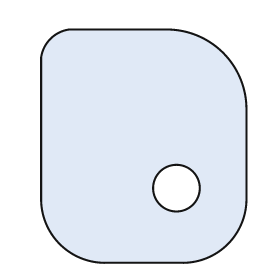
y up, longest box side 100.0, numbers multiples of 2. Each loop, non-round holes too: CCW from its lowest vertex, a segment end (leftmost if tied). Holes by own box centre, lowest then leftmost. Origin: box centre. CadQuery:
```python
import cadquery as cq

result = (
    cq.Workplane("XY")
    .moveTo(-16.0, -50.0)
    .lineTo(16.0, -50.0)
    .threePointArc((36.0, -42.0), (44.0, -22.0))
    .lineTo(44.0, 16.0)
    .threePointArc((34.0, 40.0), (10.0, 50.0))
    .lineTo(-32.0, 50.0)
    .threePointArc((-40.0, 46.0), (-44.0, 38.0))
    .lineTo(-44.0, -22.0)
    .threePointArc((-36.0, -42.0), (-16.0, -50.0))
    .close()
    .moveTo(14.0, -18.0)
    .circle(10.0)
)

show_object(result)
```